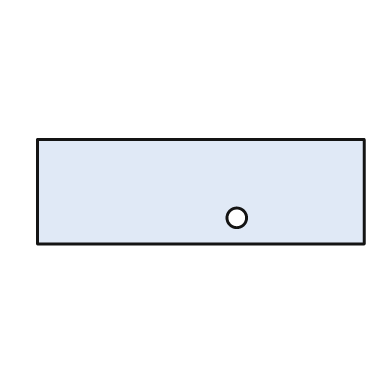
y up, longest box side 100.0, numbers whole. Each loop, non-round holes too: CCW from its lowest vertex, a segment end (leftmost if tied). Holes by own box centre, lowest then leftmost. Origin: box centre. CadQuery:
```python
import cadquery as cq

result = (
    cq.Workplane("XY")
    .moveTo(-50.0, -16.0)
    .lineTo(50.0, -16.0)
    .lineTo(50.0, 16.0)
    .lineTo(-50.0, 16.0)
    .close()
    .moveTo(11.0, -8.0)
    .circle(3.0)
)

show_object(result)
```